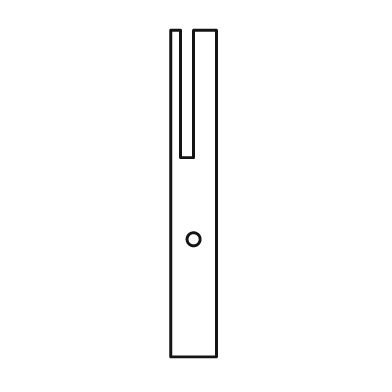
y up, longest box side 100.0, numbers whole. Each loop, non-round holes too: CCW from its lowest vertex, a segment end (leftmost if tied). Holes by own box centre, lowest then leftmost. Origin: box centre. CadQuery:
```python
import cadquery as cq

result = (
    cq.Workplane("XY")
    .moveTo(-7.0, -50.0)
    .lineTo(7.0, -50.0)
    .lineTo(7.0, 50.0)
    .lineTo(0.0, 50.0)
    .lineTo(0.0, 11.0)
    .lineTo(-4.0, 11.0)
    .lineTo(-4.0, 50.0)
    .lineTo(-7.0, 50.0)
    .close()
    .moveTo(0.0, -14.0)
    .circle(2.0)
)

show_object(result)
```